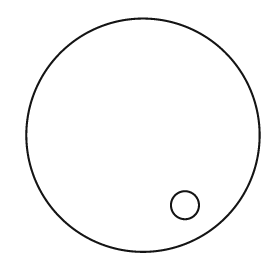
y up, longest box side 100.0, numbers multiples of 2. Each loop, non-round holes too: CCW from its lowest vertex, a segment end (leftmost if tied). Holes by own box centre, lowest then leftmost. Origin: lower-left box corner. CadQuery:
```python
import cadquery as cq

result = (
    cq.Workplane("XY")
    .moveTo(50.0, 50.0)
    .circle(50.0)
    .moveTo(68.0, 20.0)
    .circle(6.0)
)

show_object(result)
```